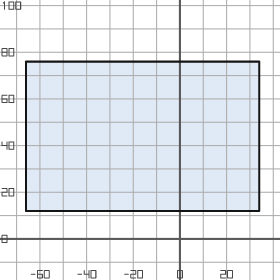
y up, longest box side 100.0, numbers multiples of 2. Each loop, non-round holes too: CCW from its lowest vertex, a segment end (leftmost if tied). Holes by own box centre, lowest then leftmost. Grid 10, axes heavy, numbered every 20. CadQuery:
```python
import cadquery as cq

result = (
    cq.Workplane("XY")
    .moveTo(-66.0, 12.0)
    .lineTo(34.0, 12.0)
    .lineTo(34.0, 76.0)
    .lineTo(-66.0, 76.0)
    .close()
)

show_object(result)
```